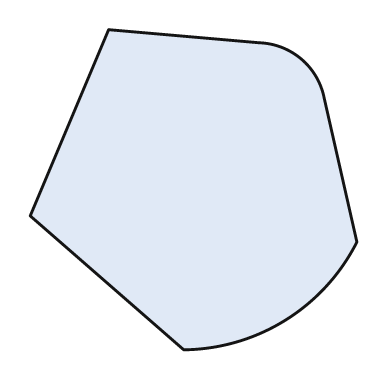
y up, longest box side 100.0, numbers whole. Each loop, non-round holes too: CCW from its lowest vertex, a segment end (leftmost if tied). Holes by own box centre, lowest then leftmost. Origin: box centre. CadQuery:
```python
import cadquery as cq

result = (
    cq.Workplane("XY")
    .moveTo(-3.0, -49.0)
    .threePointArc((28.0, -40.0), (50.0, -16.0))
    .lineTo(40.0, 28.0)
    .threePointArc((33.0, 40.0), (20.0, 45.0))
    .lineTo(-26.0, 49.0)
    .lineTo(-50.0, -8.0)
    .close()
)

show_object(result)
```